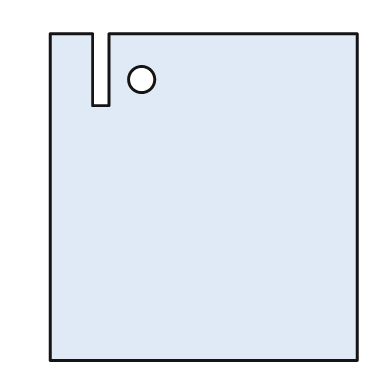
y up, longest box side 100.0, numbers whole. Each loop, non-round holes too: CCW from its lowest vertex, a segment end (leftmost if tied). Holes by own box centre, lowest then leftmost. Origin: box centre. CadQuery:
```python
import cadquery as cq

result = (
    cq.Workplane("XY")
    .moveTo(-47.0, -50.0)
    .lineTo(47.0, -50.0)
    .lineTo(47.0, 50.0)
    .lineTo(-29.0, 50.0)
    .lineTo(-29.0, 28.0)
    .lineTo(-34.0, 28.0)
    .lineTo(-34.0, 50.0)
    .lineTo(-47.0, 50.0)
    .close()
    .moveTo(-19.0, 36.0)
    .circle(4.0)
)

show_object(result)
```